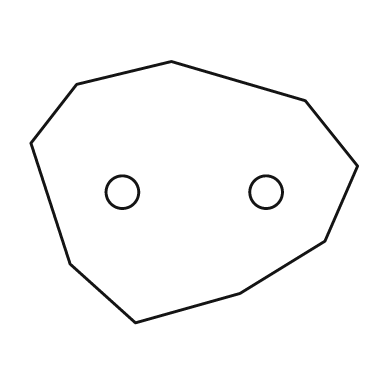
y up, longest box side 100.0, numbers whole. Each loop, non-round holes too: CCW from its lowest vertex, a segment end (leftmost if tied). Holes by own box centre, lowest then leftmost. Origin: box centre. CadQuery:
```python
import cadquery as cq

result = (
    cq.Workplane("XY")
    .moveTo(-18.0, -40.0)
    .lineTo(14.0, -31.0)
    .lineTo(40.0, -15.0)
    .lineTo(50.0, 8.0)
    .lineTo(34.0, 28.0)
    .lineTo(-7.0, 40.0)
    .lineTo(-36.0, 33.0)
    .lineTo(-50.0, 15.0)
    .lineTo(-38.0, -22.0)
    .close()
    .moveTo(-22.0, 0.0)
    .circle(5.0)
    .moveTo(22.0, 0.0)
    .circle(5.0)
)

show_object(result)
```